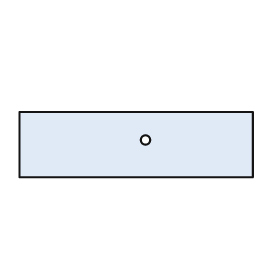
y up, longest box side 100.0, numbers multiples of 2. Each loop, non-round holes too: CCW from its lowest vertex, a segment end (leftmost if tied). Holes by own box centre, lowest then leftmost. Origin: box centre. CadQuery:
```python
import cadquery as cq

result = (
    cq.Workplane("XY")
    .moveTo(-50.0, -14.0)
    .lineTo(50.0, -14.0)
    .lineTo(50.0, 14.0)
    .lineTo(-50.0, 14.0)
    .close()
    .moveTo(4.0, 2.0)
    .circle(2.0)
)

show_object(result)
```